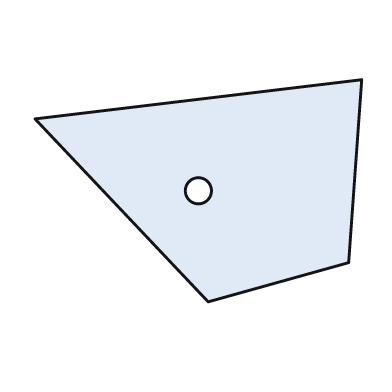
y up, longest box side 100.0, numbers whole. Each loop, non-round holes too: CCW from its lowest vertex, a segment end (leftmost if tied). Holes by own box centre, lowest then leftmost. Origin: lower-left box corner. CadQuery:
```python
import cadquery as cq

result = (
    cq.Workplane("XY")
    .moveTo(53.0, 0.0)
    .lineTo(96.0, 12.0)
    .lineTo(100.0, 68.0)
    .lineTo(0.0, 56.0)
    .close()
    .moveTo(50.0, 34.0)
    .circle(4.0)
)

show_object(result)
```